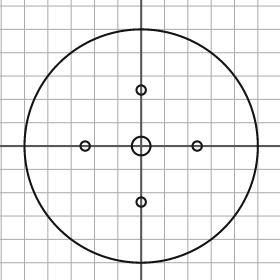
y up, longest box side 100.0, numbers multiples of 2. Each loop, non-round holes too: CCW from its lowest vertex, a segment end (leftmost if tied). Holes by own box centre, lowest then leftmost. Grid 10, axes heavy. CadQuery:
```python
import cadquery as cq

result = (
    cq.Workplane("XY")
    .moveTo(0.0, 0.0)
    .circle(50.0)
    .moveTo(0.0, -24.0)
    .circle(2.0)
    .moveTo(-24.0, 0.0)
    .circle(2.0)
    .moveTo(0.0, 0.0)
    .circle(4.0)
    .moveTo(24.0, 0.0)
    .circle(2.0)
    .moveTo(0.0, 24.0)
    .circle(2.0)
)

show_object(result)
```